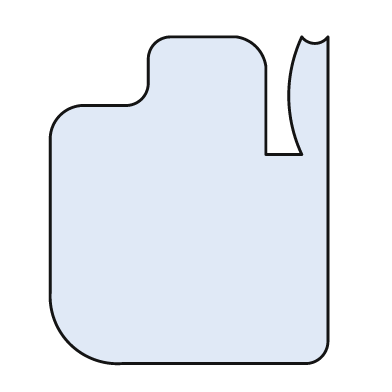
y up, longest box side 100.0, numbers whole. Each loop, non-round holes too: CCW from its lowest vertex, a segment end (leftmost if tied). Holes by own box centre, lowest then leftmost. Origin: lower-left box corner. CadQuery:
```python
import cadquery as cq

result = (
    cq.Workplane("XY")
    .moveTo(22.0, 0.0)
    .lineTo(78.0, 0.0)
    .threePointArc((83.0, 2.0), (85.0, 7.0))
    .lineTo(85.0, 100.0)
    .threePointArc((81.0, 98.0), (77.0, 100.0))
    .threePointArc((73.0, 82.0), (77.0, 64.0))
    .lineTo(66.0, 64.0)
    .lineTo(66.0, 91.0)
    .threePointArc((63.0, 97.0), (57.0, 100.0))
    .lineTo(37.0, 100.0)
    .threePointArc((32.0, 98.0), (30.0, 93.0))
    .lineTo(30.0, 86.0)
    .threePointArc((28.0, 81.0), (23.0, 79.0))
    .lineTo(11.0, 79.0)
    .threePointArc((3.0, 76.0), (0.0, 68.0))
    .lineTo(0.0, 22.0)
    .threePointArc((6.0, 6.0), (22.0, 0.0))
    .close()
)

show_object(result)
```